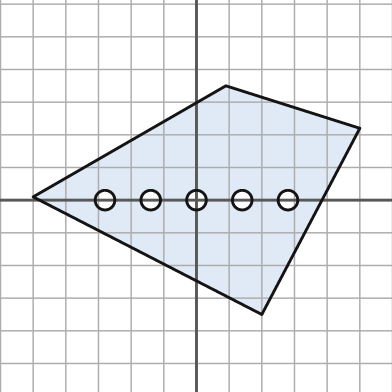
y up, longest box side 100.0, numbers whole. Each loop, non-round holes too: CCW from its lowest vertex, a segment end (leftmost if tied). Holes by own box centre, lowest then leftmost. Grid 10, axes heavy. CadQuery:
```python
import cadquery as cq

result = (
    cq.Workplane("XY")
    .moveTo(20.0, -35.0)
    .lineTo(50.0, 22.0)
    .lineTo(9.0, 35.0)
    .lineTo(-50.0, 1.0)
    .close()
    .moveTo(-28.0, 0.0)
    .circle(3.0)
    .moveTo(-14.0, 0.0)
    .circle(3.0)
    .moveTo(0.0, 0.0)
    .circle(3.0)
    .moveTo(14.0, 0.0)
    .circle(3.0)
    .moveTo(28.0, 0.0)
    .circle(3.0)
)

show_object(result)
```